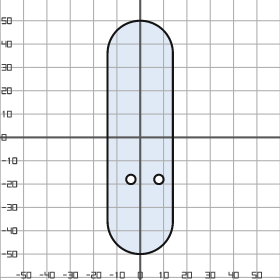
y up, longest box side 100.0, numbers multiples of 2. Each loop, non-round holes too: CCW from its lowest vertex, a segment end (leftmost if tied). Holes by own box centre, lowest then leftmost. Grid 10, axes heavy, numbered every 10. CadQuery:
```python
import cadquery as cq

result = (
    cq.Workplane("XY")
    .moveTo(-14.0, -36.0)
    .threePointArc((0.0, -50.0), (14.0, -36.0))
    .lineTo(14.0, 36.0)
    .threePointArc((0.0, 50.0), (-14.0, 36.0))
    .close()
    .moveTo(-4.0, -18.0)
    .circle(2.0)
    .moveTo(8.0, -18.0)
    .circle(2.0)
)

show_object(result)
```